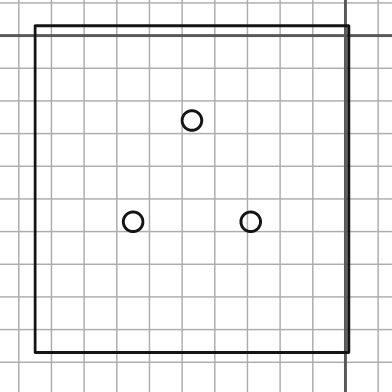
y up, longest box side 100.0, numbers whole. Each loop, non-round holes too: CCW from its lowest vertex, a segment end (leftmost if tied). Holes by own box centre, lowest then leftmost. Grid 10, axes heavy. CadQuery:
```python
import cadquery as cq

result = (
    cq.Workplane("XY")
    .moveTo(-95.0, -97.0)
    .lineTo(1.0, -97.0)
    .lineTo(1.0, 3.0)
    .lineTo(-95.0, 3.0)
    .close()
    .moveTo(-65.0, -57.0)
    .circle(3.0)
    .moveTo(-29.0, -57.0)
    .circle(3.0)
    .moveTo(-47.0, -26.0)
    .circle(3.0)
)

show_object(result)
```